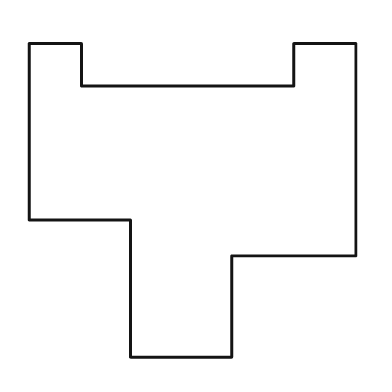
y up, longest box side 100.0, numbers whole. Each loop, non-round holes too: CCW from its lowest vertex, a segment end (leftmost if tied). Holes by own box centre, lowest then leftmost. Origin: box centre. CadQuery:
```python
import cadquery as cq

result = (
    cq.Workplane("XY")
    .moveTo(-19.0, -48.0)
    .lineTo(12.0, -48.0)
    .lineTo(12.0, -17.0)
    .lineTo(50.0, -17.0)
    .lineTo(50.0, 48.0)
    .lineTo(31.0, 48.0)
    .lineTo(31.0, 35.0)
    .lineTo(-34.0, 35.0)
    .lineTo(-34.0, 48.0)
    .lineTo(-50.0, 48.0)
    .lineTo(-50.0, -6.0)
    .lineTo(-19.0, -6.0)
    .close()
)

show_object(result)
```